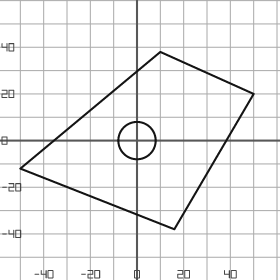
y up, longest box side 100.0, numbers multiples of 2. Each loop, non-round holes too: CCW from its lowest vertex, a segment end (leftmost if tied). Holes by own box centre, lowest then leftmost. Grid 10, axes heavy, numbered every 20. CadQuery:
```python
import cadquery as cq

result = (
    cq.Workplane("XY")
    .moveTo(16.0, -38.0)
    .lineTo(50.0, 20.0)
    .lineTo(10.0, 38.0)
    .lineTo(-50.0, -12.0)
    .close()
    .moveTo(0.0, 0.0)
    .circle(8.0)
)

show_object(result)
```